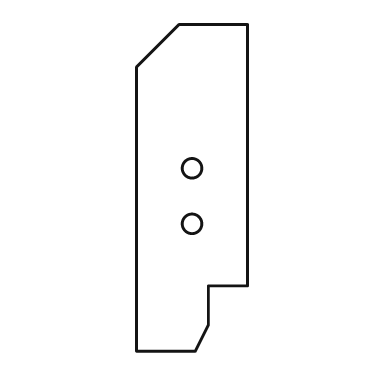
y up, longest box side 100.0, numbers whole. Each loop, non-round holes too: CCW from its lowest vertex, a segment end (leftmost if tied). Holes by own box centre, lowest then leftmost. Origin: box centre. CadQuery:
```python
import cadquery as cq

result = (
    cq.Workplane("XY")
    .moveTo(-17.0, -50.0)
    .lineTo(1.0, -50.0)
    .lineTo(5.0, -42.0)
    .lineTo(5.0, -30.0)
    .lineTo(17.0, -30.0)
    .lineTo(17.0, 50.0)
    .lineTo(-4.0, 50.0)
    .lineTo(-17.0, 37.0)
    .close()
    .moveTo(0.0, -11.0)
    .circle(3.0)
    .moveTo(0.0, 6.0)
    .circle(3.0)
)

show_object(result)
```